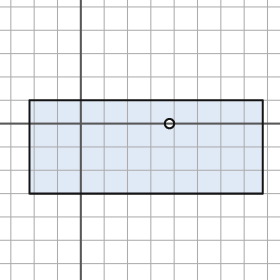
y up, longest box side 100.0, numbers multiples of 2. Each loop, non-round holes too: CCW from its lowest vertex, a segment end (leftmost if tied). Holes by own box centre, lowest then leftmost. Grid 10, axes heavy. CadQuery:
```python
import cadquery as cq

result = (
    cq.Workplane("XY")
    .moveTo(-22.0, -30.0)
    .lineTo(78.0, -30.0)
    .lineTo(78.0, 10.0)
    .lineTo(-22.0, 10.0)
    .close()
    .moveTo(38.0, 0.0)
    .circle(2.0)
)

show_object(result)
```